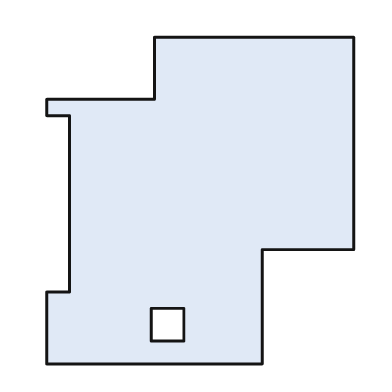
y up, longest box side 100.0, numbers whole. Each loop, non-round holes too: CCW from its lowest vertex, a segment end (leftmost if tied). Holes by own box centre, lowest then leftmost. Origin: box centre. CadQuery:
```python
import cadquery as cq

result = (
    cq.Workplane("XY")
    .moveTo(-47.0, -50.0)
    .lineTo(19.0, -50.0)
    .lineTo(19.0, -15.0)
    .lineTo(47.0, -15.0)
    .lineTo(47.0, 50.0)
    .lineTo(-14.0, 50.0)
    .lineTo(-14.0, 31.0)
    .lineTo(-47.0, 31.0)
    .lineTo(-47.0, 26.0)
    .lineTo(-40.0, 26.0)
    .lineTo(-40.0, -28.0)
    .lineTo(-47.0, -28.0)
    .close()
    .moveTo(-15.0, -43.0)
    .lineTo(-5.0, -43.0)
    .lineTo(-5.0, -33.0)
    .lineTo(-15.0, -33.0)
    .close()
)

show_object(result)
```